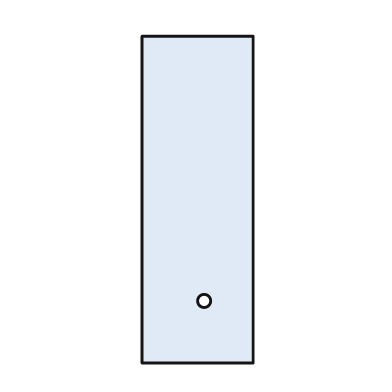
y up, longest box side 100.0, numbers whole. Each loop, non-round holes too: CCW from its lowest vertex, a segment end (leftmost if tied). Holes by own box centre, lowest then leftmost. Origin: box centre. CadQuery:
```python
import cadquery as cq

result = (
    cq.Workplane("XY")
    .moveTo(-17.0, -50.0)
    .lineTo(17.0, -50.0)
    .lineTo(17.0, 50.0)
    .lineTo(-17.0, 50.0)
    .close()
    .moveTo(2.0, -31.0)
    .circle(2.0)
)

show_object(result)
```